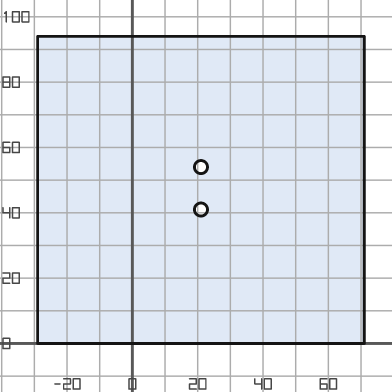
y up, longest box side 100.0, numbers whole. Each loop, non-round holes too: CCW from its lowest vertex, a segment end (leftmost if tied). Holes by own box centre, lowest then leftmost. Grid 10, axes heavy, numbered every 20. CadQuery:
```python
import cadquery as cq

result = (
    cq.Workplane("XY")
    .moveTo(-29.0, 0.0)
    .lineTo(71.0, 0.0)
    .lineTo(71.0, 94.0)
    .lineTo(-29.0, 94.0)
    .close()
    .moveTo(21.0, 41.0)
    .circle(2.0)
    .moveTo(21.0, 54.0)
    .circle(2.0)
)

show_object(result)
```